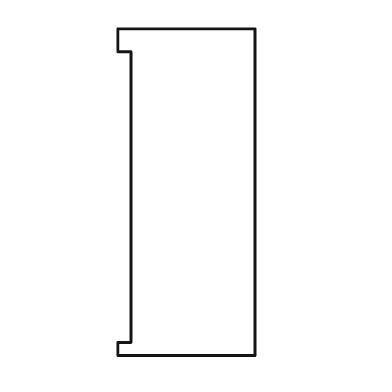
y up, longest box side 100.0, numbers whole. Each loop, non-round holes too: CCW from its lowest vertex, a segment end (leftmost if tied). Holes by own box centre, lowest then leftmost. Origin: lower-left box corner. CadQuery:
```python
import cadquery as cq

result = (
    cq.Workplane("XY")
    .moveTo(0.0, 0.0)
    .lineTo(42.0, 0.0)
    .lineTo(42.0, 100.0)
    .lineTo(0.0, 100.0)
    .lineTo(0.0, 93.0)
    .lineTo(4.0, 93.0)
    .lineTo(4.0, 4.0)
    .lineTo(0.0, 4.0)
    .close()
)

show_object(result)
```